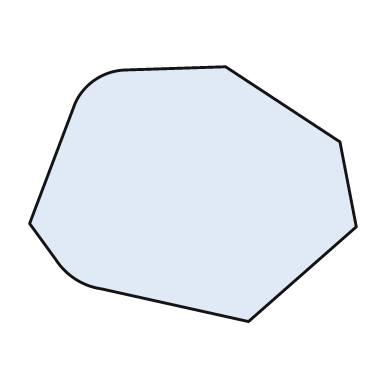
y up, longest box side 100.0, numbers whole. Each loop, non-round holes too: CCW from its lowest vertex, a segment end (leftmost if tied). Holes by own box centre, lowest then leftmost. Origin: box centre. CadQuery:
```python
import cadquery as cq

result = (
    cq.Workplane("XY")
    .moveTo(17.0, -39.0)
    .lineTo(50.0, -10.0)
    .lineTo(45.0, 16.0)
    .lineTo(10.0, 39.0)
    .lineTo(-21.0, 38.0)
    .threePointArc((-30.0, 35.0), (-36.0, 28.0))
    .lineTo(-50.0, -9.0)
    .lineTo(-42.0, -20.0)
    .threePointArc((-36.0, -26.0), (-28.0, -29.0))
    .close()
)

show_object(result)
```